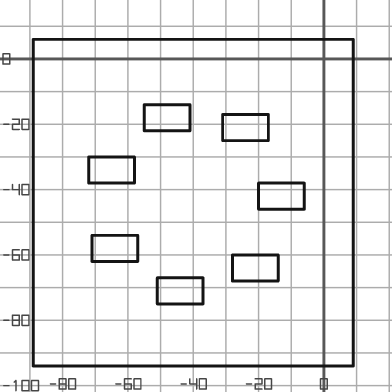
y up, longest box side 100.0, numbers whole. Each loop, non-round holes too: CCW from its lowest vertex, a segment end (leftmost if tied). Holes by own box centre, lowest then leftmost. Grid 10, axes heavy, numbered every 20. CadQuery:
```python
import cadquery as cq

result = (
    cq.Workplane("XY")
    .moveTo(-89.0, -94.0)
    .lineTo(9.0, -94.0)
    .lineTo(9.0, 6.0)
    .lineTo(-89.0, 6.0)
    .close()
    .moveTo(-51.0, -75.0)
    .lineTo(-37.0, -75.0)
    .lineTo(-37.0, -67.0)
    .lineTo(-51.0, -67.0)
    .close()
    .moveTo(-28.0, -68.0)
    .lineTo(-14.0, -68.0)
    .lineTo(-14.0, -60.0)
    .lineTo(-28.0, -60.0)
    .close()
    .moveTo(-71.0, -62.0)
    .lineTo(-57.0, -62.0)
    .lineTo(-57.0, -54.0)
    .lineTo(-71.0, -54.0)
    .close()
    .moveTo(-20.0, -46.0)
    .lineTo(-6.0, -46.0)
    .lineTo(-6.0, -38.0)
    .lineTo(-20.0, -38.0)
    .close()
    .moveTo(-72.0, -38.0)
    .lineTo(-58.0, -38.0)
    .lineTo(-58.0, -30.0)
    .lineTo(-72.0, -30.0)
    .close()
    .moveTo(-31.0, -25.0)
    .lineTo(-17.0, -25.0)
    .lineTo(-17.0, -17.0)
    .lineTo(-31.0, -17.0)
    .close()
    .moveTo(-55.0, -22.0)
    .lineTo(-41.0, -22.0)
    .lineTo(-41.0, -14.0)
    .lineTo(-55.0, -14.0)
    .close()
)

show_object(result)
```